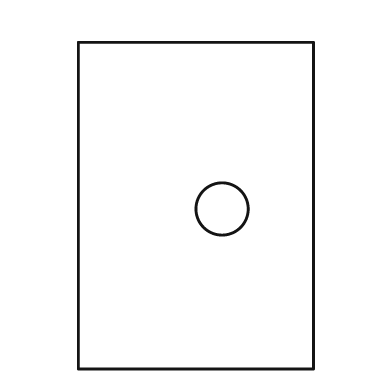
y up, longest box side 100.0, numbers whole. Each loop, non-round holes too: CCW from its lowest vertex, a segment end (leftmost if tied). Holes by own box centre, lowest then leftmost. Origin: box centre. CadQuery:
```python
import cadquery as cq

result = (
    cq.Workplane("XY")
    .moveTo(-36.0, -50.0)
    .lineTo(36.0, -50.0)
    .lineTo(36.0, 50.0)
    .lineTo(-36.0, 50.0)
    .close()
    .moveTo(8.0, -1.0)
    .circle(8.0)
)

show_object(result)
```